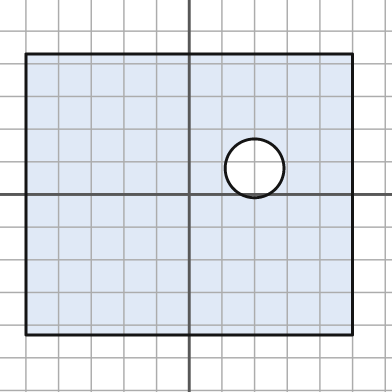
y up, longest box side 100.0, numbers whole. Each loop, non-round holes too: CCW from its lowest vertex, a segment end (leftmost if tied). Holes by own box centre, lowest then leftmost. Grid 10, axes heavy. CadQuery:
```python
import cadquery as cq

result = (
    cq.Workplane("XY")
    .moveTo(-50.0, -43.0)
    .lineTo(50.0, -43.0)
    .lineTo(50.0, 43.0)
    .lineTo(-50.0, 43.0)
    .close()
    .moveTo(20.0, 8.0)
    .circle(9.0)
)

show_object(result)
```